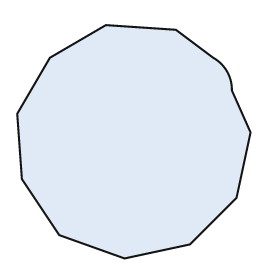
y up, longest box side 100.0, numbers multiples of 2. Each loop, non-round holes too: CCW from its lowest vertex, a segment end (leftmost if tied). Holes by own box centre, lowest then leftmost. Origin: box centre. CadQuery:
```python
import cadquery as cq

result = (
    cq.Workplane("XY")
    .moveTo(-4.0, -50.0)
    .lineTo(24.0, -44.0)
    .lineTo(44.0, -24.0)
    .lineTo(50.0, 4.0)
    .lineTo(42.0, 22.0)
    .threePointArc((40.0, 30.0), (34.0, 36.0))
    .lineTo(18.0, 48.0)
    .lineTo(-12.0, 50.0)
    .lineTo(-36.0, 36.0)
    .lineTo(-50.0, 12.0)
    .lineTo(-48.0, -16.0)
    .lineTo(-32.0, -40.0)
    .close()
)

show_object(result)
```